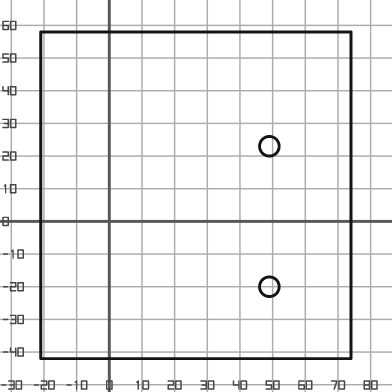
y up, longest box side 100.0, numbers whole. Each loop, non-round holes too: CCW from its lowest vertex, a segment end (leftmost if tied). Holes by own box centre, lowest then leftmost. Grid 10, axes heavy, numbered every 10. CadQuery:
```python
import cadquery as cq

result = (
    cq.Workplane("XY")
    .moveTo(-21.0, -42.0)
    .lineTo(74.0, -42.0)
    .lineTo(74.0, 58.0)
    .lineTo(-21.0, 58.0)
    .close()
    .moveTo(49.0, -20.0)
    .circle(3.0)
    .moveTo(49.0, 23.0)
    .circle(3.0)
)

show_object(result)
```